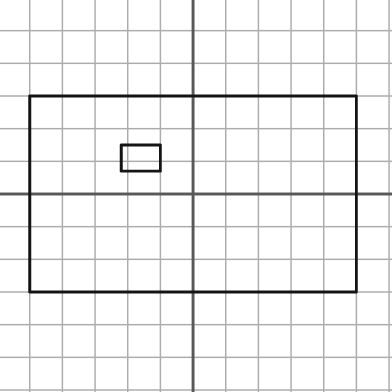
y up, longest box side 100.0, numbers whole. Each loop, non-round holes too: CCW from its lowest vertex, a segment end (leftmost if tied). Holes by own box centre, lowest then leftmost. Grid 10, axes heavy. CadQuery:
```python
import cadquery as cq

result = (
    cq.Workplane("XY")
    .moveTo(-50.0, -30.0)
    .lineTo(50.0, -30.0)
    .lineTo(50.0, 30.0)
    .lineTo(-50.0, 30.0)
    .close()
    .moveTo(-22.0, 7.0)
    .lineTo(-10.0, 7.0)
    .lineTo(-10.0, 15.0)
    .lineTo(-22.0, 15.0)
    .close()
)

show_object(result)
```